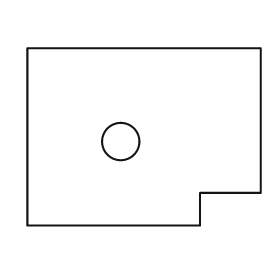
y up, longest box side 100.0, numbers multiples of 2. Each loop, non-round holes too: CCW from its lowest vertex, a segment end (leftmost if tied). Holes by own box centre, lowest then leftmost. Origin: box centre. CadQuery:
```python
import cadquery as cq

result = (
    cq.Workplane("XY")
    .moveTo(-50.0, -38.0)
    .lineTo(24.0, -38.0)
    .lineTo(24.0, -24.0)
    .lineTo(50.0, -24.0)
    .lineTo(50.0, 38.0)
    .lineTo(-50.0, 38.0)
    .close()
    .moveTo(-10.0, -2.0)
    .circle(8.0)
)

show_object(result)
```